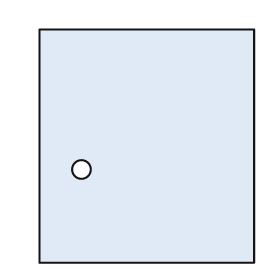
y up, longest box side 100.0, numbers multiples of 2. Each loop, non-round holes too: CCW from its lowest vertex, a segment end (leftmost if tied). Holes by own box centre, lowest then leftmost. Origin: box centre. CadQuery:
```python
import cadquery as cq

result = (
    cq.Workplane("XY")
    .moveTo(-46.0, -50.0)
    .lineTo(46.0, -50.0)
    .lineTo(46.0, 50.0)
    .lineTo(-46.0, 50.0)
    .close()
    .moveTo(-28.0, -10.0)
    .circle(4.0)
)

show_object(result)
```